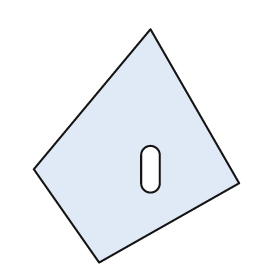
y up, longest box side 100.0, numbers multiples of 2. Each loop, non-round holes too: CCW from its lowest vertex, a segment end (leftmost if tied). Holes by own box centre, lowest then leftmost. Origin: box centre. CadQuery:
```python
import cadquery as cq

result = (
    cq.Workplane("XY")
    .moveTo(-16.0, -50.0)
    .lineTo(44.0, -16.0)
    .lineTo(6.0, 50.0)
    .lineTo(-44.0, -10.0)
    .close()
    .moveTo(2.0, -16.0)
    .threePointArc((6.0, -20.0), (10.0, -16.0))
    .lineTo(10.0, -4.0)
    .threePointArc((6.0, 0.0), (2.0, -4.0))
    .close()
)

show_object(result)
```